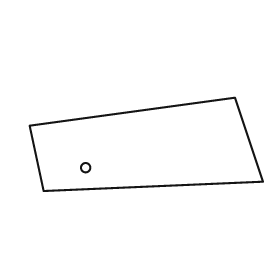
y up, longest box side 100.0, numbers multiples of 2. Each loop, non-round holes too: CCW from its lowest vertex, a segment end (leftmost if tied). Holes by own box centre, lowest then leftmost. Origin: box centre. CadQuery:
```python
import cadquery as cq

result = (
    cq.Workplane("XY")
    .moveTo(-44.0, -20.0)
    .lineTo(50.0, -16.0)
    .lineTo(38.0, 20.0)
    .lineTo(-50.0, 8.0)
    .close()
    .moveTo(-26.0, -10.0)
    .circle(2.0)
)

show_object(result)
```